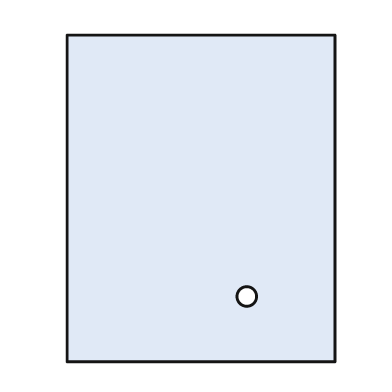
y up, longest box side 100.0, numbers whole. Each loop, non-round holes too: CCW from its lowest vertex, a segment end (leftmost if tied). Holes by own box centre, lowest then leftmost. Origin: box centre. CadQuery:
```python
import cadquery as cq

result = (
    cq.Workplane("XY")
    .moveTo(-41.0, -50.0)
    .lineTo(41.0, -50.0)
    .lineTo(41.0, 50.0)
    .lineTo(-41.0, 50.0)
    .close()
    .moveTo(14.0, -30.0)
    .circle(3.0)
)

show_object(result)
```